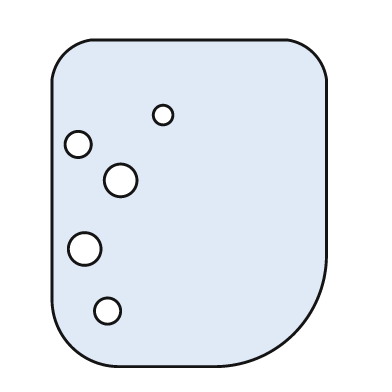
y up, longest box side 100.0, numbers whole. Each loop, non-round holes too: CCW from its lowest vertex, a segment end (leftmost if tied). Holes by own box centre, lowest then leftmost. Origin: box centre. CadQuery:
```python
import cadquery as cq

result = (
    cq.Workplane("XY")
    .moveTo(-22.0, -50.0)
    .lineTo(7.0, -50.0)
    .threePointArc((32.0, -40.0), (42.0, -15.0))
    .lineTo(42.0, 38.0)
    .threePointArc((38.0, 46.0), (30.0, 50.0))
    .lineTo(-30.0, 50.0)
    .threePointArc((-38.0, 46.0), (-42.0, 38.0))
    .lineTo(-42.0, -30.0)
    .threePointArc((-36.0, -44.0), (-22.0, -50.0))
    .close()
    .moveTo(-25.0, -33.0)
    .circle(4.0)
    .moveTo(-32.0, -14.0)
    .circle(5.0)
    .moveTo(-21.0, 7.0)
    .circle(5.0)
    .moveTo(-34.0, 18.0)
    .circle(4.0)
    .moveTo(-8.0, 27.0)
    .circle(3.0)
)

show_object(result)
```